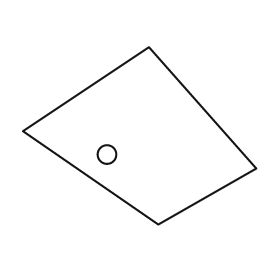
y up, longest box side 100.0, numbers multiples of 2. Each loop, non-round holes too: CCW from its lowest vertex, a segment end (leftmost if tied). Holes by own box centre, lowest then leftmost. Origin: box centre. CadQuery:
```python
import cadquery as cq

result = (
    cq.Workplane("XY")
    .moveTo(8.0, -38.0)
    .lineTo(50.0, -14.0)
    .lineTo(4.0, 38.0)
    .lineTo(-50.0, 2.0)
    .close()
    .moveTo(-14.0, -8.0)
    .circle(4.0)
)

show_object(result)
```